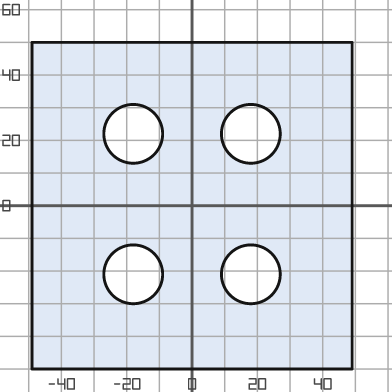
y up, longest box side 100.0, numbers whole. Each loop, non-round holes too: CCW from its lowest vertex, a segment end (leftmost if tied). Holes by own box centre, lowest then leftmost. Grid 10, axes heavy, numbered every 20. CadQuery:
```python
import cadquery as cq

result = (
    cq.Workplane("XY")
    .moveTo(-49.0, -50.0)
    .lineTo(49.0, -50.0)
    .lineTo(49.0, 50.0)
    .lineTo(-49.0, 50.0)
    .close()
    .moveTo(-18.0, -21.0)
    .circle(9.0)
    .moveTo(18.0, -21.0)
    .circle(9.0)
    .moveTo(-18.0, 22.0)
    .circle(9.0)
    .moveTo(18.0, 22.0)
    .circle(9.0)
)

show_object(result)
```